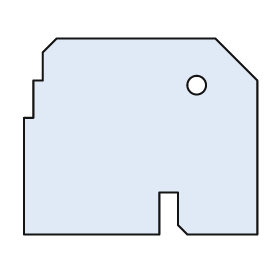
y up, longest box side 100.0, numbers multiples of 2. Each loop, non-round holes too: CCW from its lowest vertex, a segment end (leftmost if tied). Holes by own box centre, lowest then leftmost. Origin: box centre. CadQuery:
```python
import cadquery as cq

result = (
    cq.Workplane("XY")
    .moveTo(-50.0, -42.0)
    .lineTo(8.0, -42.0)
    .lineTo(8.0, -24.0)
    .lineTo(16.0, -24.0)
    .lineTo(16.0, -38.0)
    .lineTo(20.0, -42.0)
    .lineTo(50.0, -42.0)
    .lineTo(50.0, 24.0)
    .lineTo(32.0, 42.0)
    .lineTo(-36.0, 42.0)
    .lineTo(-42.0, 36.0)
    .lineTo(-42.0, 24.0)
    .lineTo(-46.0, 24.0)
    .lineTo(-46.0, 8.0)
    .lineTo(-50.0, 8.0)
    .close()
    .moveTo(24.0, 22.0)
    .circle(4.0)
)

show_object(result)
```